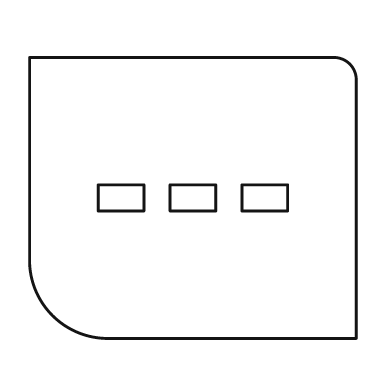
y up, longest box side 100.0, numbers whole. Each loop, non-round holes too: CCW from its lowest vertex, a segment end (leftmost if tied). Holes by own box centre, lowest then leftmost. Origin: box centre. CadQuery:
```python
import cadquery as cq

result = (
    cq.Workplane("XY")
    .moveTo(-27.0, -43.0)
    .lineTo(50.0, -43.0)
    .lineTo(50.0, 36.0)
    .threePointArc((48.0, 41.0), (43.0, 43.0))
    .lineTo(-50.0, 43.0)
    .lineTo(-50.0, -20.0)
    .threePointArc((-43.0, -36.0), (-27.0, -43.0))
    .close()
    .moveTo(-29.0, -4.0)
    .lineTo(-15.0, -4.0)
    .lineTo(-15.0, 4.0)
    .lineTo(-29.0, 4.0)
    .close()
    .moveTo(-7.0, -4.0)
    .lineTo(7.0, -4.0)
    .lineTo(7.0, 4.0)
    .lineTo(-7.0, 4.0)
    .close()
    .moveTo(15.0, -4.0)
    .lineTo(29.0, -4.0)
    .lineTo(29.0, 4.0)
    .lineTo(15.0, 4.0)
    .close()
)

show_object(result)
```